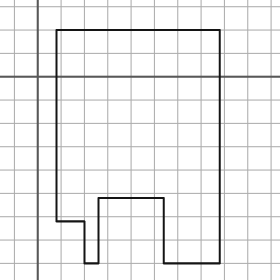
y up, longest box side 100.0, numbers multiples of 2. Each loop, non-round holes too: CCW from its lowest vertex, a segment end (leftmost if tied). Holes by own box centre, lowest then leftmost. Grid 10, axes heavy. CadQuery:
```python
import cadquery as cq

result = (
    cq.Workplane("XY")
    .moveTo(20.0, -80.0)
    .lineTo(26.0, -80.0)
    .lineTo(26.0, -52.0)
    .lineTo(54.0, -52.0)
    .lineTo(54.0, -80.0)
    .lineTo(78.0, -80.0)
    .lineTo(78.0, 20.0)
    .lineTo(8.0, 20.0)
    .lineTo(8.0, -62.0)
    .lineTo(20.0, -62.0)
    .close()
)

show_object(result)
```